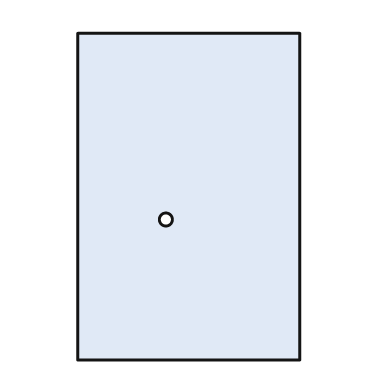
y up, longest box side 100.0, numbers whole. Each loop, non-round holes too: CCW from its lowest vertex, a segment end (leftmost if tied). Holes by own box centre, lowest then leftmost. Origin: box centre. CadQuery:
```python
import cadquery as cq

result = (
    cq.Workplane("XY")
    .moveTo(-34.0, -50.0)
    .lineTo(34.0, -50.0)
    .lineTo(34.0, 50.0)
    .lineTo(-34.0, 50.0)
    .close()
    .moveTo(-7.0, -7.0)
    .circle(2.0)
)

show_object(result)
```